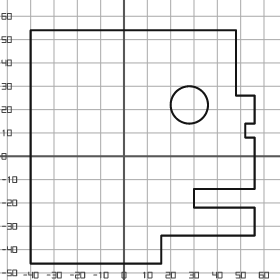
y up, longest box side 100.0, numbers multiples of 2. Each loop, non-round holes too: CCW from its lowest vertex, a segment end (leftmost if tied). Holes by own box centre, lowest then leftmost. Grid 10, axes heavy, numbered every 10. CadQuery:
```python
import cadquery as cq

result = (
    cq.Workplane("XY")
    .moveTo(-40.0, -46.0)
    .lineTo(16.0, -46.0)
    .lineTo(16.0, -34.0)
    .lineTo(56.0, -34.0)
    .lineTo(56.0, -22.0)
    .lineTo(30.0, -22.0)
    .lineTo(30.0, -14.0)
    .lineTo(56.0, -14.0)
    .lineTo(56.0, 8.0)
    .lineTo(52.0, 8.0)
    .lineTo(52.0, 14.0)
    .lineTo(56.0, 14.0)
    .lineTo(56.0, 26.0)
    .lineTo(48.0, 26.0)
    .lineTo(48.0, 54.0)
    .lineTo(-40.0, 54.0)
    .close()
    .moveTo(28.0, 22.0)
    .circle(8.0)
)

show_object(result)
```